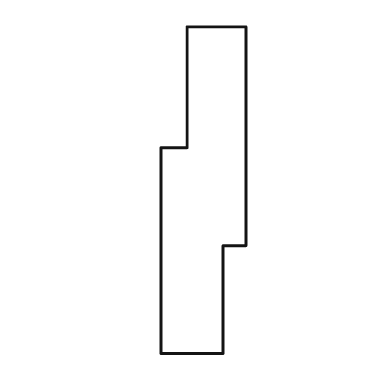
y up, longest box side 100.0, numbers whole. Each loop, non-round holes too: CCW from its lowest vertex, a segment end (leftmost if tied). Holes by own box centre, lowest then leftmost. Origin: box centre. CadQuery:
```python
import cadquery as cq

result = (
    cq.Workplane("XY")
    .moveTo(-13.0, -50.0)
    .lineTo(6.0, -50.0)
    .lineTo(6.0, -17.0)
    .lineTo(13.0, -17.0)
    .lineTo(13.0, 50.0)
    .lineTo(-5.0, 50.0)
    .lineTo(-5.0, 13.0)
    .lineTo(-13.0, 13.0)
    .close()
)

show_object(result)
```